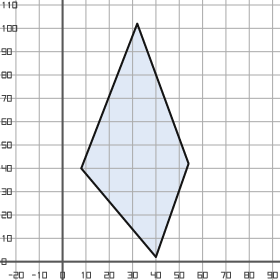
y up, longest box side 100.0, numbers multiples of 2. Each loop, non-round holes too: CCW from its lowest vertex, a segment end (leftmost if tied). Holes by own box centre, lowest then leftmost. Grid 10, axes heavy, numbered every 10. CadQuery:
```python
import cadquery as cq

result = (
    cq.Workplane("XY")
    .moveTo(40.0, 2.0)
    .lineTo(54.0, 42.0)
    .lineTo(32.0, 102.0)
    .lineTo(8.0, 40.0)
    .close()
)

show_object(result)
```